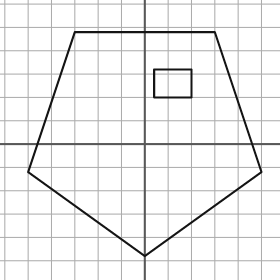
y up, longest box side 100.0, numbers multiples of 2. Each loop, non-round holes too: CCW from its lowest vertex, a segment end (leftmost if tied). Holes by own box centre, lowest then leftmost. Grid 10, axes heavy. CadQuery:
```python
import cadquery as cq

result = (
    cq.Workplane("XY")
    .moveTo(0.0, -48.0)
    .lineTo(50.0, -12.0)
    .lineTo(30.0, 48.0)
    .lineTo(-30.0, 48.0)
    .lineTo(-50.0, -12.0)
    .close()
    .moveTo(4.0, 20.0)
    .lineTo(20.0, 20.0)
    .lineTo(20.0, 32.0)
    .lineTo(4.0, 32.0)
    .close()
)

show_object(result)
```